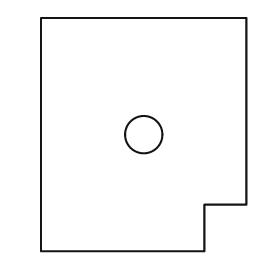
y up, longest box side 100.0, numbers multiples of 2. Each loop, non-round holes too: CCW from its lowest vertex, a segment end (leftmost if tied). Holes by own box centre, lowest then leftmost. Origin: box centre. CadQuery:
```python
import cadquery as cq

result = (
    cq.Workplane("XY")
    .moveTo(-44.0, -50.0)
    .lineTo(26.0, -50.0)
    .lineTo(26.0, -30.0)
    .lineTo(44.0, -30.0)
    .lineTo(44.0, 50.0)
    .lineTo(-44.0, 50.0)
    .close()
    .moveTo(0.0, 0.0)
    .circle(8.0)
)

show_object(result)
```